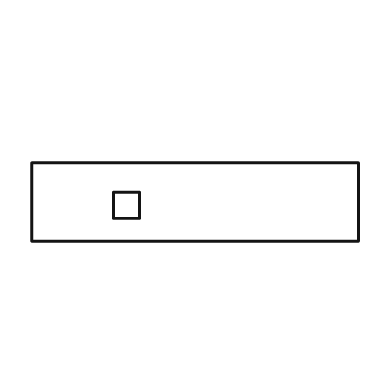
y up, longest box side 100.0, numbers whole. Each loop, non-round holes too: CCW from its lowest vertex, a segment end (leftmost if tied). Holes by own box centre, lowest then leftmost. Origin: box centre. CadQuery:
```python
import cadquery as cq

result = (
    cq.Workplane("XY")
    .moveTo(-50.0, -12.0)
    .lineTo(50.0, -12.0)
    .lineTo(50.0, 12.0)
    .lineTo(-50.0, 12.0)
    .close()
    .moveTo(-25.0, -5.0)
    .lineTo(-17.0, -5.0)
    .lineTo(-17.0, 3.0)
    .lineTo(-25.0, 3.0)
    .close()
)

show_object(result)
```